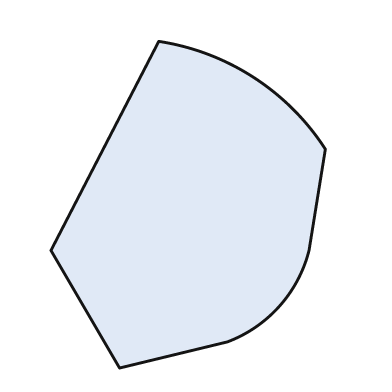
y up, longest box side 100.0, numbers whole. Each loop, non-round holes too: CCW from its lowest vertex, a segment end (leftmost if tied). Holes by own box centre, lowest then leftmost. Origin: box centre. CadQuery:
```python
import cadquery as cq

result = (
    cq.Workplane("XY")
    .moveTo(-21.0, -50.0)
    .lineTo(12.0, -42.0)
    .threePointArc((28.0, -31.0), (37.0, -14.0))
    .lineTo(42.0, 17.0)
    .threePointArc((20.0, 39.0), (-9.0, 50.0))
    .lineTo(-42.0, -14.0)
    .close()
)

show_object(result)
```